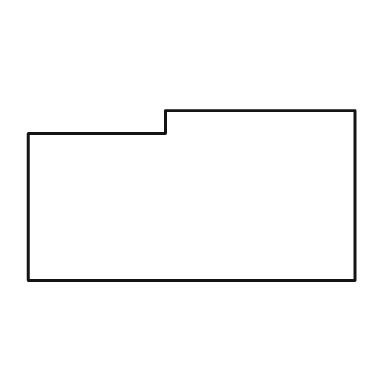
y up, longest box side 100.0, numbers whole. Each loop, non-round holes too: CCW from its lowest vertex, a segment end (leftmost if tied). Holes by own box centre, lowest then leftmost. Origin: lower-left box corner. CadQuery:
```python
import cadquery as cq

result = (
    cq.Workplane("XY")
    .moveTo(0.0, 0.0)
    .lineTo(100.0, 0.0)
    .lineTo(100.0, 52.0)
    .lineTo(42.0, 52.0)
    .lineTo(42.0, 45.0)
    .lineTo(0.0, 45.0)
    .close()
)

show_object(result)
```